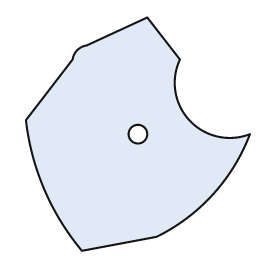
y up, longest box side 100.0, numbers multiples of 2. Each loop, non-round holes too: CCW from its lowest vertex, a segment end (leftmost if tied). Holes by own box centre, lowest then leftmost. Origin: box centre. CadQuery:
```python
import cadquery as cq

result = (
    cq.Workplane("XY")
    .moveTo(-24.0, -50.0)
    .lineTo(8.0, -44.0)
    .threePointArc((32.0, -26.0), (48.0, 0.0))
    .threePointArc((22.0, 6.0), (18.0, 32.0))
    .lineTo(4.0, 50.0)
    .lineTo(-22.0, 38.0)
    .threePointArc((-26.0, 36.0), (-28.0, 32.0))
    .lineTo(-48.0, 6.0)
    .threePointArc((-40.0, -24.0), (-24.0, -50.0))
    .close()
    .moveTo(0.0, 0.0)
    .circle(4.0)
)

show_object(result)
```